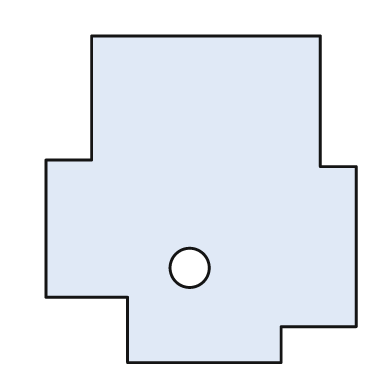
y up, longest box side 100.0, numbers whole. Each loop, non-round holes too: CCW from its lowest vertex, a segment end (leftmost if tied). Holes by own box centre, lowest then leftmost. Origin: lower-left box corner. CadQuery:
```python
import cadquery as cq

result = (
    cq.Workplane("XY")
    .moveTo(25.0, 0.0)
    .lineTo(72.0, 0.0)
    .lineTo(72.0, 11.0)
    .lineTo(95.0, 11.0)
    .lineTo(95.0, 60.0)
    .lineTo(84.0, 60.0)
    .lineTo(84.0, 100.0)
    .lineTo(14.0, 100.0)
    .lineTo(14.0, 62.0)
    .lineTo(0.0, 62.0)
    .lineTo(0.0, 20.0)
    .lineTo(25.0, 20.0)
    .close()
    .moveTo(44.0, 29.0)
    .circle(6.0)
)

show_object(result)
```